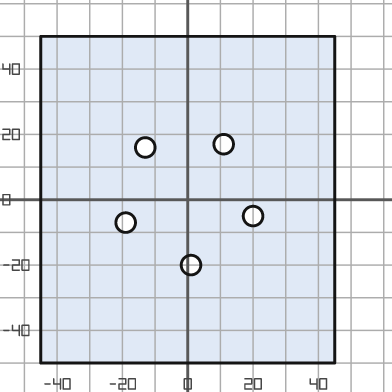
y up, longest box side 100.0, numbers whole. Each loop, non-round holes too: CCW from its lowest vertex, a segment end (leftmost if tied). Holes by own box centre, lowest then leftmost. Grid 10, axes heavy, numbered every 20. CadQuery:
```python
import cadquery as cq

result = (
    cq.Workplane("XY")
    .moveTo(-45.0, -50.0)
    .lineTo(45.0, -50.0)
    .lineTo(45.0, 50.0)
    .lineTo(-45.0, 50.0)
    .close()
    .moveTo(1.0, -20.0)
    .circle(3.0)
    .moveTo(-19.0, -7.0)
    .circle(3.0)
    .moveTo(20.0, -5.0)
    .circle(3.0)
    .moveTo(-13.0, 16.0)
    .circle(3.0)
    .moveTo(11.0, 17.0)
    .circle(3.0)
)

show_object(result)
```